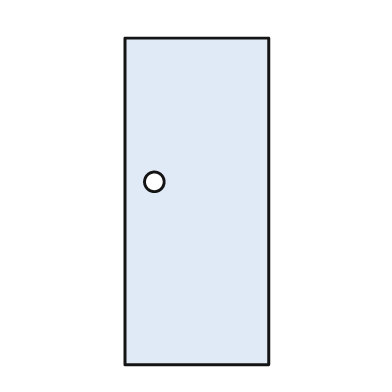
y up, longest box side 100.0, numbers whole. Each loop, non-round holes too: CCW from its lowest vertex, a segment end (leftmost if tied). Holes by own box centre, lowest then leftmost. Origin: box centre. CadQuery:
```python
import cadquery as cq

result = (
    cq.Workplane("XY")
    .moveTo(-22.0, -50.0)
    .lineTo(22.0, -50.0)
    .lineTo(22.0, 50.0)
    .lineTo(-22.0, 50.0)
    .close()
    .moveTo(-13.0, 6.0)
    .circle(3.0)
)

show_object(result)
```